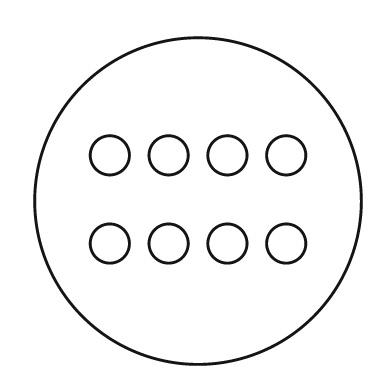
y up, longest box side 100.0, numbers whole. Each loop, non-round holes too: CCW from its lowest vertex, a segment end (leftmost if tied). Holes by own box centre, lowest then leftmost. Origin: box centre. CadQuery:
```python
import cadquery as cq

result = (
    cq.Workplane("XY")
    .moveTo(0.0, 0.0)
    .circle(50.0)
    .moveTo(-27.0, -13.0)
    .circle(6.0)
    .moveTo(-9.0, -13.0)
    .circle(6.0)
    .moveTo(9.0, -13.0)
    .circle(6.0)
    .moveTo(27.0, -13.0)
    .circle(6.0)
    .moveTo(-27.0, 14.0)
    .circle(6.0)
    .moveTo(-9.0, 14.0)
    .circle(6.0)
    .moveTo(9.0, 14.0)
    .circle(6.0)
    .moveTo(27.0, 14.0)
    .circle(6.0)
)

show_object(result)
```